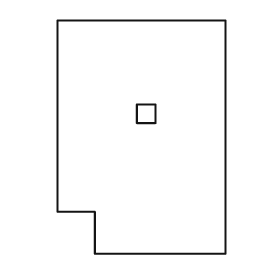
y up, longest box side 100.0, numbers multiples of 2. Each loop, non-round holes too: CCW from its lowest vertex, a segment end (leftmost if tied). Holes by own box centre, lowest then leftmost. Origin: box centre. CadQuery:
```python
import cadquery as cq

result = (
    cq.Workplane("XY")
    .moveTo(-20.0, -50.0)
    .lineTo(36.0, -50.0)
    .lineTo(36.0, 50.0)
    .lineTo(-36.0, 50.0)
    .lineTo(-36.0, -32.0)
    .lineTo(-20.0, -32.0)
    .close()
    .moveTo(-2.0, 6.0)
    .lineTo(6.0, 6.0)
    .lineTo(6.0, 14.0)
    .lineTo(-2.0, 14.0)
    .close()
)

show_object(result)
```